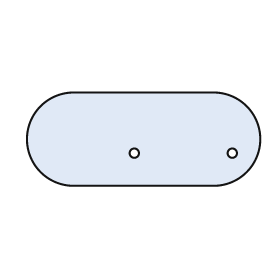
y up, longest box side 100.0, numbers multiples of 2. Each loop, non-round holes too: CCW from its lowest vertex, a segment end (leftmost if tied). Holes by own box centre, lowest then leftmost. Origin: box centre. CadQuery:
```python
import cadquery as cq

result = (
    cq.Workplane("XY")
    .moveTo(-30.0, -20.0)
    .lineTo(30.0, -20.0)
    .threePointArc((50.0, 0.0), (30.0, 20.0))
    .lineTo(-30.0, 20.0)
    .threePointArc((-50.0, 0.0), (-30.0, -20.0))
    .close()
    .moveTo(-4.0, -6.0)
    .circle(2.0)
    .moveTo(38.0, -6.0)
    .circle(2.0)
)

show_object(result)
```